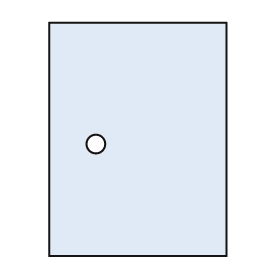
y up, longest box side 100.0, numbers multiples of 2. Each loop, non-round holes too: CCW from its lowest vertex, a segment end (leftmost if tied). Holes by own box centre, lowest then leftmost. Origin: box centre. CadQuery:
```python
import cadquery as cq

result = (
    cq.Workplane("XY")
    .moveTo(-38.0, -50.0)
    .lineTo(38.0, -50.0)
    .lineTo(38.0, 50.0)
    .lineTo(-38.0, 50.0)
    .close()
    .moveTo(-18.0, -2.0)
    .circle(4.0)
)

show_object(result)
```